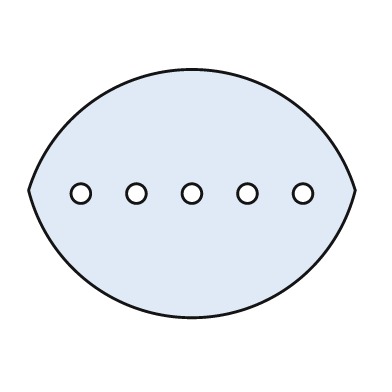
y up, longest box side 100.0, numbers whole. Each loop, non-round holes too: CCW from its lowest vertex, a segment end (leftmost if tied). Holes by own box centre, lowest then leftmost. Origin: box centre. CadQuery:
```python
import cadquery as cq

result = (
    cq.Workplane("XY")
    .moveTo(-50.0, 1.0)
    .threePointArc((0.0, -38.0), (50.0, 1.0))
    .threePointArc((0.0, 38.0), (-50.0, 1.0))
    .close()
    .moveTo(-34.0, 0.0)
    .circle(3.0)
    .moveTo(-17.0, 0.0)
    .circle(3.0)
    .moveTo(0.0, 0.0)
    .circle(3.0)
    .moveTo(17.0, 0.0)
    .circle(3.0)
    .moveTo(34.0, 0.0)
    .circle(3.0)
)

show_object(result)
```